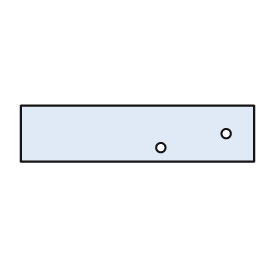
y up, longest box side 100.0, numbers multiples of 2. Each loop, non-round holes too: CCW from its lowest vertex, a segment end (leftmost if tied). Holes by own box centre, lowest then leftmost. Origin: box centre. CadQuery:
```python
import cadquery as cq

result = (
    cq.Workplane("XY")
    .moveTo(-50.0, -12.0)
    .lineTo(50.0, -12.0)
    .lineTo(50.0, 12.0)
    .lineTo(-50.0, 12.0)
    .close()
    .moveTo(10.0, -6.0)
    .circle(2.0)
    .moveTo(38.0, 0.0)
    .circle(2.0)
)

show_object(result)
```